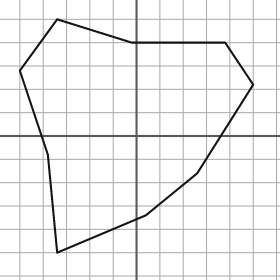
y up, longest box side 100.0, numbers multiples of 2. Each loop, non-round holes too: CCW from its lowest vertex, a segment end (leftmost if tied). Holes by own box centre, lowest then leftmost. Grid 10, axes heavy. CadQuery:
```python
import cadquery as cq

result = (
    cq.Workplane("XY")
    .moveTo(-34.0, -50.0)
    .lineTo(4.0, -34.0)
    .lineTo(26.0, -16.0)
    .lineTo(50.0, 22.0)
    .lineTo(38.0, 40.0)
    .lineTo(-2.0, 40.0)
    .lineTo(-34.0, 50.0)
    .lineTo(-50.0, 28.0)
    .lineTo(-38.0, -8.0)
    .close()
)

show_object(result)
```